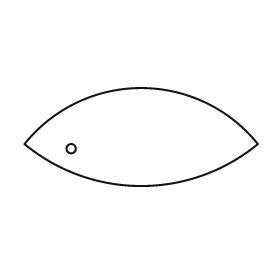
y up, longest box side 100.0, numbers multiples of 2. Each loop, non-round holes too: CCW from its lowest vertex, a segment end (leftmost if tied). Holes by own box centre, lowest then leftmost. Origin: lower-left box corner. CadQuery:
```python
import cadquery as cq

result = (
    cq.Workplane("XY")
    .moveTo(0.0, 18.0)
    .threePointArc((50.0, 0.0), (100.0, 18.0))
    .threePointArc((50.0, 42.0), (0.0, 18.0))
    .close()
    .moveTo(20.0, 16.0)
    .circle(2.0)
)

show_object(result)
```